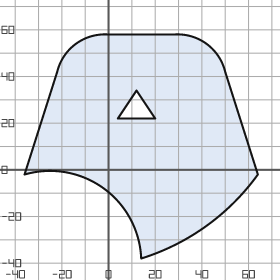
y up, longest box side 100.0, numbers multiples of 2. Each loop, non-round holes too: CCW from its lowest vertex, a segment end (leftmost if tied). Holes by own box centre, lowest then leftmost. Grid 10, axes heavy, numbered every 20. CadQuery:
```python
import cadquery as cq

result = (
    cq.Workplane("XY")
    .moveTo(14.0, -38.0)
    .threePointArc((42.0, -24.0), (64.0, -2.0))
    .lineTo(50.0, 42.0)
    .threePointArc((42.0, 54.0), (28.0, 58.0))
    .lineTo(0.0, 58.0)
    .threePointArc((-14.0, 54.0), (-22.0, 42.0))
    .lineTo(-36.0, -2.0)
    .threePointArc((-2.0, -8.0), (14.0, -38.0))
    .close()
    .moveTo(4.0, 22.0)
    .lineTo(20.0, 22.0)
    .lineTo(12.0, 34.0)
    .close()
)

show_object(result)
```